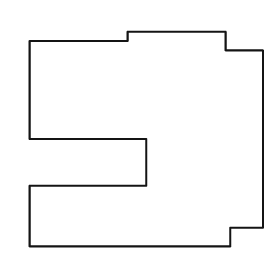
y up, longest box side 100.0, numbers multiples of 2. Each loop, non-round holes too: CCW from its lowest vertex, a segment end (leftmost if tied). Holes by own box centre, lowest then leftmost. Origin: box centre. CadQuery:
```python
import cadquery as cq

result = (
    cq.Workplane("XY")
    .moveTo(-50.0, -46.0)
    .lineTo(36.0, -46.0)
    .lineTo(36.0, -38.0)
    .lineTo(50.0, -38.0)
    .lineTo(50.0, 38.0)
    .lineTo(34.0, 38.0)
    .lineTo(34.0, 46.0)
    .lineTo(-8.0, 46.0)
    .lineTo(-8.0, 42.0)
    .lineTo(-50.0, 42.0)
    .lineTo(-50.0, 0.0)
    .lineTo(0.0, 0.0)
    .lineTo(0.0, -20.0)
    .lineTo(-50.0, -20.0)
    .close()
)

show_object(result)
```